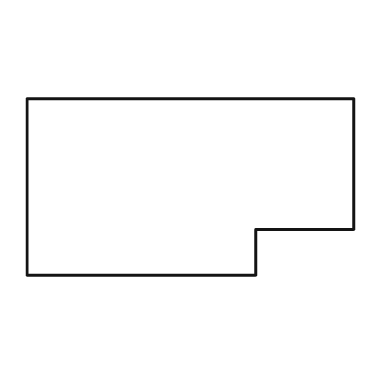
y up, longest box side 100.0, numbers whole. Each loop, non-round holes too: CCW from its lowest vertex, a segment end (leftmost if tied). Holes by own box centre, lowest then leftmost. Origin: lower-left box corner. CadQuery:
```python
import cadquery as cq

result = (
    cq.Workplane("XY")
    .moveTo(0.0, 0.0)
    .lineTo(70.0, 0.0)
    .lineTo(70.0, 14.0)
    .lineTo(100.0, 14.0)
    .lineTo(100.0, 54.0)
    .lineTo(0.0, 54.0)
    .close()
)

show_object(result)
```